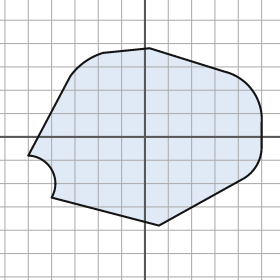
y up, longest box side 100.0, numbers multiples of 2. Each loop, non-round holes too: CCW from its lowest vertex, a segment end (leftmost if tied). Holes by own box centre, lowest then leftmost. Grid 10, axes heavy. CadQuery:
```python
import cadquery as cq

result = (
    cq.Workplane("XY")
    .moveTo(6.0, -38.0)
    .lineTo(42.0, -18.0)
    .threePointArc((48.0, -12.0), (50.0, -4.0))
    .lineTo(50.0, 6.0)
    .threePointArc((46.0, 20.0), (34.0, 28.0))
    .lineTo(2.0, 38.0)
    .lineTo(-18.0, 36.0)
    .threePointArc((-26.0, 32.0), (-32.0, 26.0))
    .lineTo(-50.0, -8.0)
    .threePointArc((-40.0, -14.0), (-40.0, -26.0))
    .close()
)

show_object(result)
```